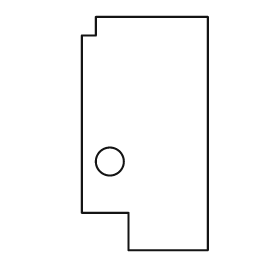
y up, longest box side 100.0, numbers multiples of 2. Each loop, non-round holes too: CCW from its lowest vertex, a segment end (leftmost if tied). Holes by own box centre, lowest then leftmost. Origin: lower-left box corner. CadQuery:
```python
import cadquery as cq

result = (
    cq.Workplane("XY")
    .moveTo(20.0, 0.0)
    .lineTo(54.0, 0.0)
    .lineTo(54.0, 100.0)
    .lineTo(6.0, 100.0)
    .lineTo(6.0, 92.0)
    .lineTo(0.0, 92.0)
    .lineTo(0.0, 16.0)
    .lineTo(20.0, 16.0)
    .close()
    .moveTo(12.0, 38.0)
    .circle(6.0)
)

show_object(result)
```